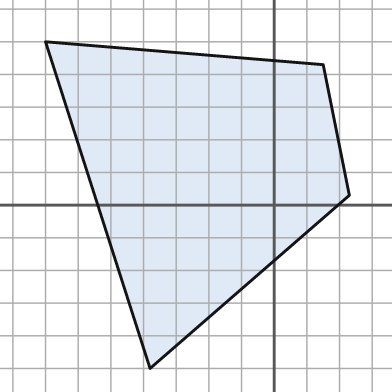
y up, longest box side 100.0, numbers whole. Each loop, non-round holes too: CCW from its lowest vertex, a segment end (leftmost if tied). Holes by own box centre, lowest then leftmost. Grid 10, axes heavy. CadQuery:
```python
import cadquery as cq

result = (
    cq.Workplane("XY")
    .moveTo(-38.0, -50.0)
    .lineTo(23.0, 3.0)
    .lineTo(15.0, 43.0)
    .lineTo(-70.0, 50.0)
    .close()
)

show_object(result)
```